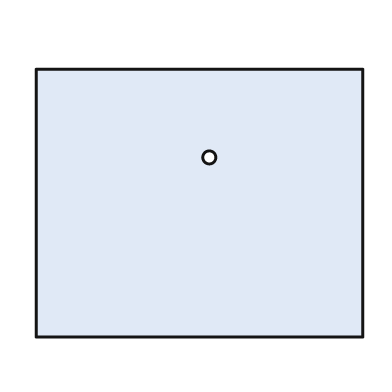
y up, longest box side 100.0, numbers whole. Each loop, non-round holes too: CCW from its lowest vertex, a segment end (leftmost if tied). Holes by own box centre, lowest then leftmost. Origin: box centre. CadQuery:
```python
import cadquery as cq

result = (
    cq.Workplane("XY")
    .moveTo(-50.0, -41.0)
    .lineTo(50.0, -41.0)
    .lineTo(50.0, 41.0)
    .lineTo(-50.0, 41.0)
    .close()
    .moveTo(3.0, 14.0)
    .circle(2.0)
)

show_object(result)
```